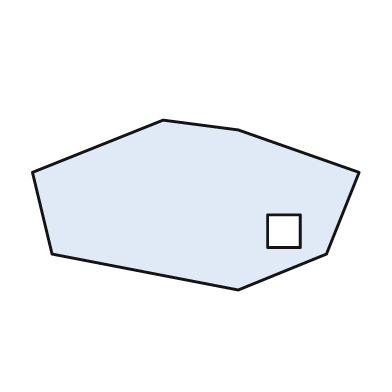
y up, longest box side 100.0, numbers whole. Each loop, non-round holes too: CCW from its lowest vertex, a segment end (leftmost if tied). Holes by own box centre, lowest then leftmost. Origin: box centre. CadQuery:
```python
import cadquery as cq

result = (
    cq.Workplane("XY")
    .moveTo(13.0, -26.0)
    .lineTo(40.0, -15.0)
    .lineTo(50.0, 10.0)
    .lineTo(13.0, 23.0)
    .lineTo(-10.0, 26.0)
    .lineTo(-50.0, 10.0)
    .lineTo(-44.0, -15.0)
    .close()
    .moveTo(22.0, -13.0)
    .lineTo(32.0, -13.0)
    .lineTo(32.0, -3.0)
    .lineTo(22.0, -3.0)
    .close()
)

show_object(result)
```